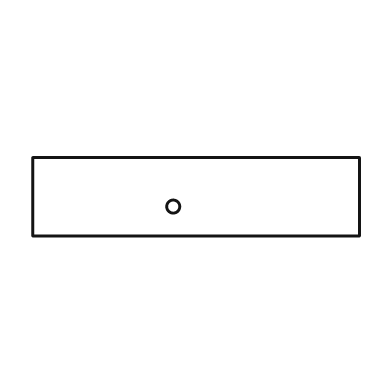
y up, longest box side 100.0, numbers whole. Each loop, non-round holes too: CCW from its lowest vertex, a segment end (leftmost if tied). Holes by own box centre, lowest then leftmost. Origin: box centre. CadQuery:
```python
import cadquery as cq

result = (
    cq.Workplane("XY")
    .moveTo(-50.0, -12.0)
    .lineTo(50.0, -12.0)
    .lineTo(50.0, 12.0)
    .lineTo(-50.0, 12.0)
    .close()
    .moveTo(-7.0, -3.0)
    .circle(2.0)
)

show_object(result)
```